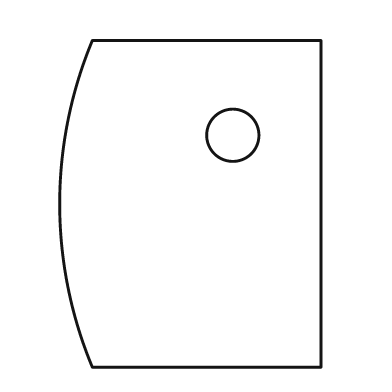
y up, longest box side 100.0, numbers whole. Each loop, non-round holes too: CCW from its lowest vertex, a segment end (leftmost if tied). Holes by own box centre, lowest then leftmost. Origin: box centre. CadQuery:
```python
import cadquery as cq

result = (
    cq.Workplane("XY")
    .moveTo(-30.0, -50.0)
    .lineTo(40.0, -50.0)
    .lineTo(40.0, 50.0)
    .lineTo(-30.0, 50.0)
    .threePointArc((-40.0, 0.0), (-30.0, -50.0))
    .close()
    .moveTo(13.0, 21.0)
    .circle(8.0)
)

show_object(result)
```